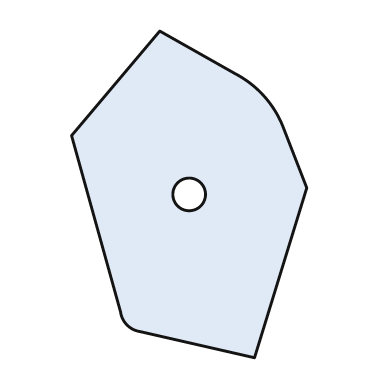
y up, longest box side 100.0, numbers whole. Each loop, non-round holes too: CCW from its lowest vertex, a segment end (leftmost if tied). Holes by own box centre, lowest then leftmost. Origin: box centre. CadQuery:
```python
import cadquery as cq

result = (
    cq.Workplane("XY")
    .moveTo(20.0, -50.0)
    .lineTo(36.0, 2.0)
    .lineTo(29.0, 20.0)
    .threePointArc((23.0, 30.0), (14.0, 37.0))
    .lineTo(-9.0, 50.0)
    .lineTo(-36.0, 18.0)
    .lineTo(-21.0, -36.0)
    .threePointArc((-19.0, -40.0), (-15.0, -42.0))
    .close()
    .moveTo(0.0, 0.0)
    .circle(5.0)
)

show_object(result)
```